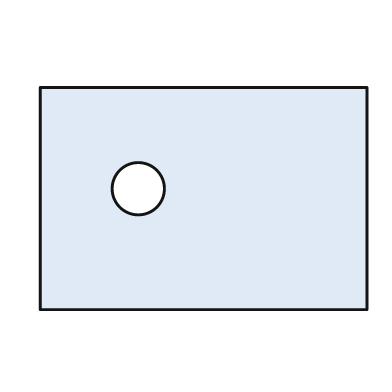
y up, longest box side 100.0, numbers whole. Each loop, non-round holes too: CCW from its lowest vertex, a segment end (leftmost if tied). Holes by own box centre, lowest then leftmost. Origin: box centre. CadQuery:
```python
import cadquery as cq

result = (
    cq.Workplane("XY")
    .moveTo(-50.0, -34.0)
    .lineTo(50.0, -34.0)
    .lineTo(50.0, 34.0)
    .lineTo(-50.0, 34.0)
    .close()
    .moveTo(-20.0, 3.0)
    .circle(8.0)
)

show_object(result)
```